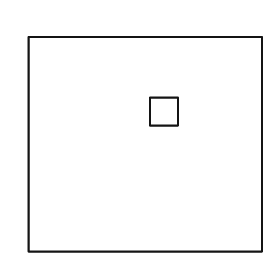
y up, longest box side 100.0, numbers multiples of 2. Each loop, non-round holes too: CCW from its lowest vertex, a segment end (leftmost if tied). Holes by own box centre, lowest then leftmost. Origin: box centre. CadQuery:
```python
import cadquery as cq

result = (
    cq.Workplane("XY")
    .moveTo(-50.0, -46.0)
    .lineTo(50.0, -46.0)
    .lineTo(50.0, 46.0)
    .lineTo(-50.0, 46.0)
    .close()
    .moveTo(2.0, 8.0)
    .lineTo(14.0, 8.0)
    .lineTo(14.0, 20.0)
    .lineTo(2.0, 20.0)
    .close()
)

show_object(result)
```